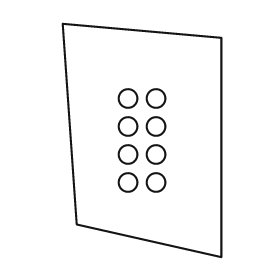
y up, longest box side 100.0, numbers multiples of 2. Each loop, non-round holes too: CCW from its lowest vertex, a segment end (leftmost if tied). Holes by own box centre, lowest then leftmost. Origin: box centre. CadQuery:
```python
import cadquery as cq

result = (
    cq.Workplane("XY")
    .moveTo(34.0, -50.0)
    .lineTo(34.0, 44.0)
    .lineTo(-34.0, 50.0)
    .lineTo(-28.0, -36.0)
    .close()
    .moveTo(-6.0, -18.0)
    .circle(4.0)
    .moveTo(6.0, -18.0)
    .circle(4.0)
    .moveTo(-6.0, -6.0)
    .circle(4.0)
    .moveTo(6.0, -6.0)
    .circle(4.0)
    .moveTo(-6.0, 6.0)
    .circle(4.0)
    .moveTo(6.0, 6.0)
    .circle(4.0)
    .moveTo(-6.0, 18.0)
    .circle(4.0)
    .moveTo(6.0, 18.0)
    .circle(4.0)
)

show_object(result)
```